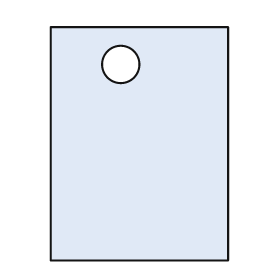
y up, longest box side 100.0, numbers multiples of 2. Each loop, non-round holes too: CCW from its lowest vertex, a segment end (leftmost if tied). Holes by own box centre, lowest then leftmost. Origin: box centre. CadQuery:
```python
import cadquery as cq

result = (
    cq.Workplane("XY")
    .moveTo(-38.0, -50.0)
    .lineTo(38.0, -50.0)
    .lineTo(38.0, 50.0)
    .lineTo(-38.0, 50.0)
    .close()
    .moveTo(-8.0, 34.0)
    .circle(8.0)
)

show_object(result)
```